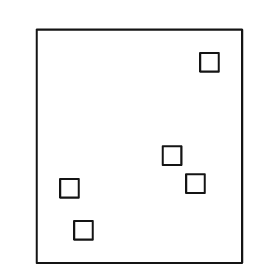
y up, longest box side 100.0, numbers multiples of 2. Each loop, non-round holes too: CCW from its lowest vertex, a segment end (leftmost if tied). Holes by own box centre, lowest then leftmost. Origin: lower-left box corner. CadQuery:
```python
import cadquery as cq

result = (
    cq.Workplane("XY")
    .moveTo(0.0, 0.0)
    .lineTo(88.0, 0.0)
    .lineTo(88.0, 100.0)
    .lineTo(0.0, 100.0)
    .close()
    .moveTo(16.0, 10.0)
    .lineTo(24.0, 10.0)
    .lineTo(24.0, 18.0)
    .lineTo(16.0, 18.0)
    .close()
    .moveTo(10.0, 28.0)
    .lineTo(18.0, 28.0)
    .lineTo(18.0, 36.0)
    .lineTo(10.0, 36.0)
    .close()
    .moveTo(64.0, 30.0)
    .lineTo(72.0, 30.0)
    .lineTo(72.0, 38.0)
    .lineTo(64.0, 38.0)
    .close()
    .moveTo(54.0, 42.0)
    .lineTo(62.0, 42.0)
    .lineTo(62.0, 50.0)
    .lineTo(54.0, 50.0)
    .close()
    .moveTo(70.0, 82.0)
    .lineTo(78.0, 82.0)
    .lineTo(78.0, 90.0)
    .lineTo(70.0, 90.0)
    .close()
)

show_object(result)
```